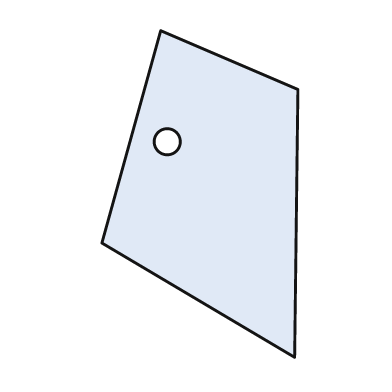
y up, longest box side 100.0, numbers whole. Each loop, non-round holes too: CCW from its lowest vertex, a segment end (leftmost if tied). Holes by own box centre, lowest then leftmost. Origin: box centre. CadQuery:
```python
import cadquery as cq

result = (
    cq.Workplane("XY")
    .moveTo(29.0, -50.0)
    .lineTo(30.0, 32.0)
    .lineTo(-12.0, 50.0)
    .lineTo(-30.0, -15.0)
    .close()
    .moveTo(-10.0, 16.0)
    .circle(4.0)
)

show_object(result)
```